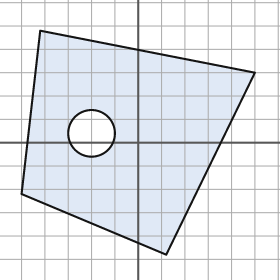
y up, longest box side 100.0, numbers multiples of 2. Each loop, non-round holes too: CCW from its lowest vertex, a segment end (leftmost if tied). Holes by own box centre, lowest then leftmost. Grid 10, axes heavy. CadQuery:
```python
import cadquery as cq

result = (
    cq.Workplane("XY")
    .moveTo(12.0, -48.0)
    .lineTo(50.0, 30.0)
    .lineTo(-42.0, 48.0)
    .lineTo(-50.0, -22.0)
    .close()
    .moveTo(-20.0, 4.0)
    .circle(10.0)
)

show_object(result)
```